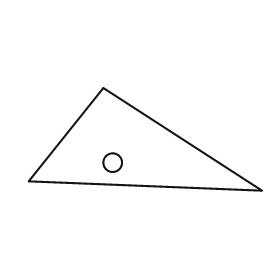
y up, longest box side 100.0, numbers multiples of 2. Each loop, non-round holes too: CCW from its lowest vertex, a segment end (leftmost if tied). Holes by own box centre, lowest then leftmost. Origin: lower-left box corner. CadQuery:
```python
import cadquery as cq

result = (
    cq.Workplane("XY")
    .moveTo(100.0, 0.0)
    .lineTo(32.0, 44.0)
    .lineTo(0.0, 4.0)
    .close()
    .moveTo(36.0, 12.0)
    .circle(4.0)
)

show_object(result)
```